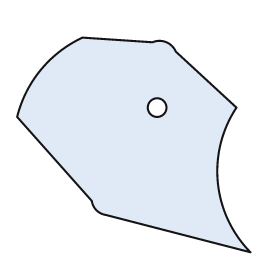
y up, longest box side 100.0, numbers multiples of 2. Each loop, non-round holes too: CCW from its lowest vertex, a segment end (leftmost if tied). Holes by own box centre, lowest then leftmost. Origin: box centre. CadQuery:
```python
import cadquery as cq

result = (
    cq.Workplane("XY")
    .moveTo(50.0, -46.0)
    .threePointArc((36.0, -16.0), (44.0, 16.0))
    .lineTo(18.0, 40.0)
    .threePointArc((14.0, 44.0), (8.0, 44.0))
    .lineTo(-22.0, 46.0)
    .threePointArc((-40.0, 32.0), (-50.0, 12.0))
    .lineTo(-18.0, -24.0)
    .threePointArc((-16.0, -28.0), (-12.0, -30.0))
    .close()
    .moveTo(10.0, 16.0)
    .circle(4.0)
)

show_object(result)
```